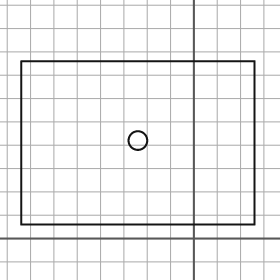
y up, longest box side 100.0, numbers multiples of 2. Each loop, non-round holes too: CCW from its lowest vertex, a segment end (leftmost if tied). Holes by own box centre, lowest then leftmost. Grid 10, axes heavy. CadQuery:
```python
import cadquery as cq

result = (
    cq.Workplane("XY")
    .moveTo(-74.0, 6.0)
    .lineTo(26.0, 6.0)
    .lineTo(26.0, 76.0)
    .lineTo(-74.0, 76.0)
    .close()
    .moveTo(-24.0, 42.0)
    .circle(4.0)
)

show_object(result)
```